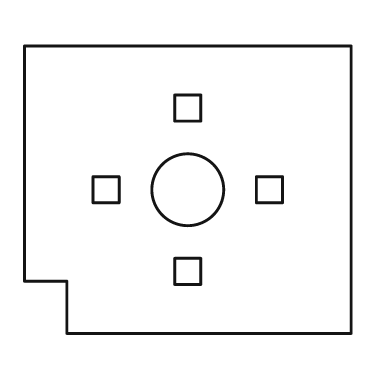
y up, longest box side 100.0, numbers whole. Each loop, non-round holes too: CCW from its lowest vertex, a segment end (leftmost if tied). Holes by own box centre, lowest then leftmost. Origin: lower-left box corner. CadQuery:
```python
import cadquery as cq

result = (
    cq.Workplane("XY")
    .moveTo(13.0, 0.0)
    .lineTo(100.0, 0.0)
    .lineTo(100.0, 88.0)
    .lineTo(0.0, 88.0)
    .lineTo(0.0, 16.0)
    .lineTo(13.0, 16.0)
    .close()
    .moveTo(46.0, 15.0)
    .lineTo(54.0, 15.0)
    .lineTo(54.0, 23.0)
    .lineTo(46.0, 23.0)
    .close()
    .moveTo(21.0, 40.0)
    .lineTo(29.0, 40.0)
    .lineTo(29.0, 48.0)
    .lineTo(21.0, 48.0)
    .close()
    .moveTo(50.0, 44.0)
    .circle(11.0)
    .moveTo(71.0, 40.0)
    .lineTo(79.0, 40.0)
    .lineTo(79.0, 48.0)
    .lineTo(71.0, 48.0)
    .close()
    .moveTo(46.0, 65.0)
    .lineTo(54.0, 65.0)
    .lineTo(54.0, 73.0)
    .lineTo(46.0, 73.0)
    .close()
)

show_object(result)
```